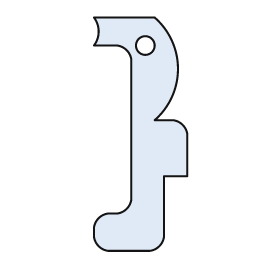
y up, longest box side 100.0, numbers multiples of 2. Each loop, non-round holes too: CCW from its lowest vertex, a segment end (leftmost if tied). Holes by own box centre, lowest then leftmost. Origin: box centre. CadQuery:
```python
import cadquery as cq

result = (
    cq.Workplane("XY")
    .moveTo(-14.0, -50.0)
    .lineTo(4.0, -50.0)
    .threePointArc((8.0, -48.0), (10.0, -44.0))
    .lineTo(10.0, -18.0)
    .lineTo(20.0, -18.0)
    .lineTo(20.0, 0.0)
    .threePointArc((18.0, 4.0), (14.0, 6.0))
    .lineTo(6.0, 6.0)
    .threePointArc((16.0, 28.0), (6.0, 50.0))
    .lineTo(-20.0, 50.0)
    .threePointArc((-18.0, 44.0), (-20.0, 38.0))
    .lineTo(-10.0, 38.0)
    .threePointArc((-6.0, 36.0), (-4.0, 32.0))
    .lineTo(-4.0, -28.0)
    .threePointArc((-6.0, -32.0), (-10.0, -34.0))
    .lineTo(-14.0, -34.0)
    .threePointArc((-18.0, -36.0), (-20.0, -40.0))
    .lineTo(-20.0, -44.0)
    .threePointArc((-18.0, -48.0), (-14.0, -50.0))
    .close()
    .moveTo(2.0, 38.0)
    .circle(4.0)
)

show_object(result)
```